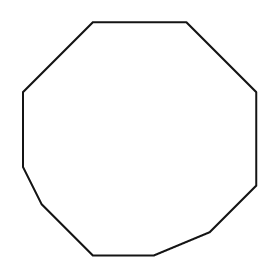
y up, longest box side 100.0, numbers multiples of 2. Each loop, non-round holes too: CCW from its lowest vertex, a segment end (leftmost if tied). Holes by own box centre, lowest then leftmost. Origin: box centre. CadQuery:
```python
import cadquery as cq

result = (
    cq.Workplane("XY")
    .moveTo(-20.0, -50.0)
    .lineTo(6.0, -50.0)
    .lineTo(30.0, -40.0)
    .lineTo(50.0, -20.0)
    .lineTo(50.0, 20.0)
    .lineTo(20.0, 50.0)
    .lineTo(-20.0, 50.0)
    .lineTo(-50.0, 20.0)
    .lineTo(-50.0, -12.0)
    .lineTo(-42.0, -28.0)
    .close()
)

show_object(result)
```